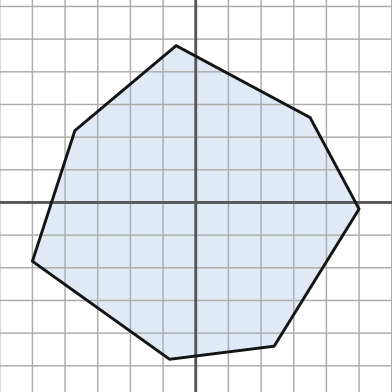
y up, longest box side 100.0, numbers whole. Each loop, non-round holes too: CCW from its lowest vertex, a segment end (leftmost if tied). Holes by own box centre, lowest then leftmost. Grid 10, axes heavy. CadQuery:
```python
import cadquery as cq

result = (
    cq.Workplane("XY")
    .moveTo(-8.0, -48.0)
    .lineTo(24.0, -44.0)
    .lineTo(50.0, -2.0)
    .lineTo(35.0, 26.0)
    .lineTo(-6.0, 48.0)
    .lineTo(-37.0, 22.0)
    .lineTo(-50.0, -18.0)
    .close()
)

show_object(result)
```